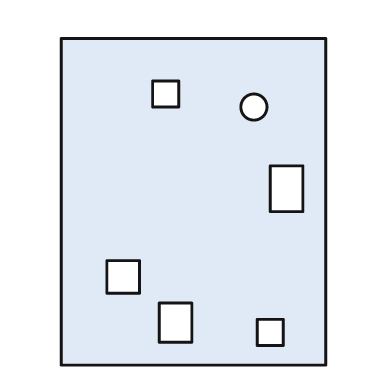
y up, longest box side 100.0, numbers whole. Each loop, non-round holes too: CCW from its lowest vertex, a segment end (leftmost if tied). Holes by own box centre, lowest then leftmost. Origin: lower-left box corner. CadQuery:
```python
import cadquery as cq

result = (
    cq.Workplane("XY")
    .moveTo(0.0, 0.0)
    .lineTo(81.0, 0.0)
    .lineTo(81.0, 100.0)
    .lineTo(0.0, 100.0)
    .close()
    .moveTo(60.0, 6.0)
    .lineTo(68.0, 6.0)
    .lineTo(68.0, 14.0)
    .lineTo(60.0, 14.0)
    .close()
    .moveTo(30.0, 7.0)
    .lineTo(40.0, 7.0)
    .lineTo(40.0, 19.0)
    .lineTo(30.0, 19.0)
    .close()
    .moveTo(14.0, 22.0)
    .lineTo(24.0, 22.0)
    .lineTo(24.0, 32.0)
    .lineTo(14.0, 32.0)
    .close()
    .moveTo(64.0, 47.0)
    .lineTo(74.0, 47.0)
    .lineTo(74.0, 61.0)
    .lineTo(64.0, 61.0)
    .close()
    .moveTo(59.0, 79.0)
    .circle(4.0)
    .moveTo(28.0, 79.0)
    .lineTo(36.0, 79.0)
    .lineTo(36.0, 87.0)
    .lineTo(28.0, 87.0)
    .close()
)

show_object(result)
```